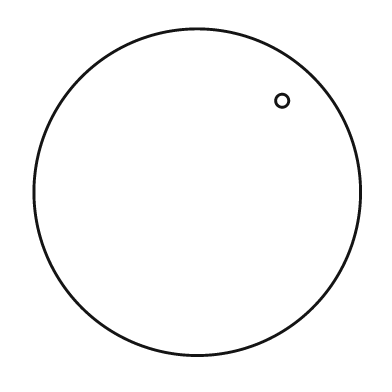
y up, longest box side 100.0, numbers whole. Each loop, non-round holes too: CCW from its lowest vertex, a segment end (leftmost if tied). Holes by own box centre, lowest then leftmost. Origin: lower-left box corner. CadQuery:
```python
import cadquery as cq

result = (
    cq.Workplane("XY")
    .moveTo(50.0, 50.0)
    .circle(50.0)
    .moveTo(76.0, 78.0)
    .circle(2.0)
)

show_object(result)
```